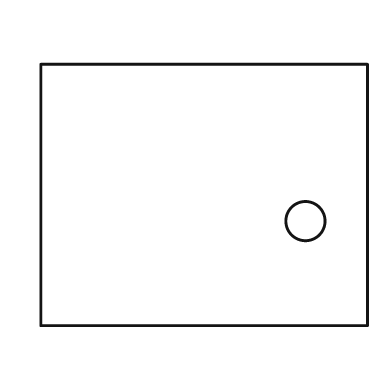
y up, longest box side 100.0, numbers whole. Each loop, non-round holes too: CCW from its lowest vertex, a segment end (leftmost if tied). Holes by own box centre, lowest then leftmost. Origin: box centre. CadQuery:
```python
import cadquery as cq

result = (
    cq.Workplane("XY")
    .moveTo(-50.0, -40.0)
    .lineTo(50.0, -40.0)
    .lineTo(50.0, 40.0)
    .lineTo(-50.0, 40.0)
    .close()
    .moveTo(31.0, -8.0)
    .circle(6.0)
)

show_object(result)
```